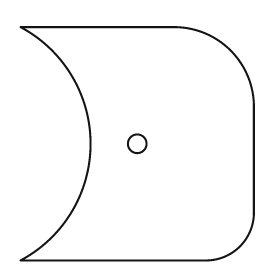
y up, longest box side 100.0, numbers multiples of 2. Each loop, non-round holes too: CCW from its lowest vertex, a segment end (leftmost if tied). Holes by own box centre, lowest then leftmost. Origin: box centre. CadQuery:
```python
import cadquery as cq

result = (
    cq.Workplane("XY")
    .moveTo(-50.0, -50.0)
    .lineTo(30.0, -50.0)
    .threePointArc((44.0, -44.0), (50.0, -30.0))
    .lineTo(50.0, 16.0)
    .threePointArc((40.0, 40.0), (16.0, 50.0))
    .lineTo(-50.0, 50.0)
    .threePointArc((-20.0, 0.0), (-50.0, -50.0))
    .close()
    .moveTo(0.0, 0.0)
    .circle(4.0)
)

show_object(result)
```